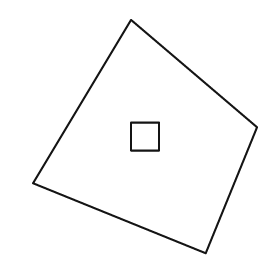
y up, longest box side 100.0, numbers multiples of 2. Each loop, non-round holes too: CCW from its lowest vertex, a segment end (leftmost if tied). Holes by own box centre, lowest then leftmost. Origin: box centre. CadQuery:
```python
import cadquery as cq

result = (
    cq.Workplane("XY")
    .moveTo(26.0, -50.0)
    .lineTo(48.0, 4.0)
    .lineTo(-6.0, 50.0)
    .lineTo(-48.0, -20.0)
    .close()
    .moveTo(-6.0, -6.0)
    .lineTo(6.0, -6.0)
    .lineTo(6.0, 6.0)
    .lineTo(-6.0, 6.0)
    .close()
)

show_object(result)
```